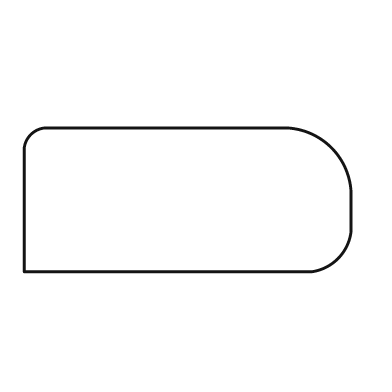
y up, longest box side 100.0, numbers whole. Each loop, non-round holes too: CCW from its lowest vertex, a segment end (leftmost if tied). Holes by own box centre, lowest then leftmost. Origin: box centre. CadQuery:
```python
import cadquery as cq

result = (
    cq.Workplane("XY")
    .moveTo(-50.0, -22.0)
    .lineTo(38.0, -22.0)
    .threePointArc((46.0, -18.0), (50.0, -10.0))
    .lineTo(50.0, 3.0)
    .threePointArc((44.0, 16.0), (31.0, 22.0))
    .lineTo(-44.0, 22.0)
    .threePointArc((-48.0, 20.0), (-50.0, 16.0))
    .close()
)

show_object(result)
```